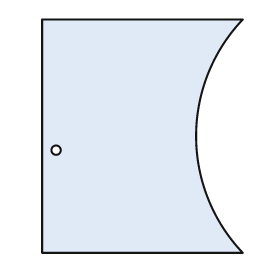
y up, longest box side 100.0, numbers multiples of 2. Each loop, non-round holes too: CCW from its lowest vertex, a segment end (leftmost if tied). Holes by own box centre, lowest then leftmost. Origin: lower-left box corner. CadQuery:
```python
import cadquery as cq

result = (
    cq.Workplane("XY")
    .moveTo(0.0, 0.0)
    .lineTo(86.0, 0.0)
    .threePointArc((66.0, 50.0), (86.0, 100.0))
    .lineTo(0.0, 100.0)
    .close()
    .moveTo(6.0, 44.0)
    .circle(2.0)
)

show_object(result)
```